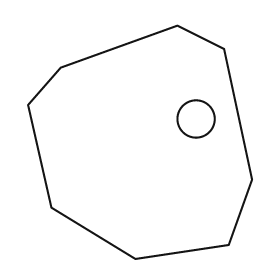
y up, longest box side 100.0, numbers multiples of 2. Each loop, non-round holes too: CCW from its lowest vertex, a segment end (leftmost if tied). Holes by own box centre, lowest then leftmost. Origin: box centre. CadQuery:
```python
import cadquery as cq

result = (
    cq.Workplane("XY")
    .moveTo(-2.0, -50.0)
    .lineTo(38.0, -44.0)
    .lineTo(48.0, -16.0)
    .lineTo(36.0, 40.0)
    .lineTo(16.0, 50.0)
    .lineTo(-34.0, 32.0)
    .lineTo(-48.0, 16.0)
    .lineTo(-38.0, -28.0)
    .close()
    .moveTo(24.0, 10.0)
    .circle(8.0)
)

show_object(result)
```